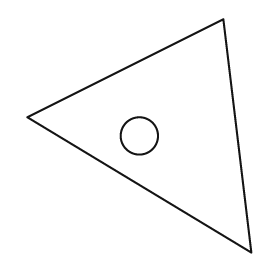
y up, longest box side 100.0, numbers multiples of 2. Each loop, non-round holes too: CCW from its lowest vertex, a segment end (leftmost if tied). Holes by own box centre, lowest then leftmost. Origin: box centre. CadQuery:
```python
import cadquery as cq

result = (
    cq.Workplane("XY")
    .moveTo(48.0, -50.0)
    .lineTo(36.0, 50.0)
    .lineTo(-48.0, 8.0)
    .close()
    .moveTo(0.0, 0.0)
    .circle(8.0)
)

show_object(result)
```